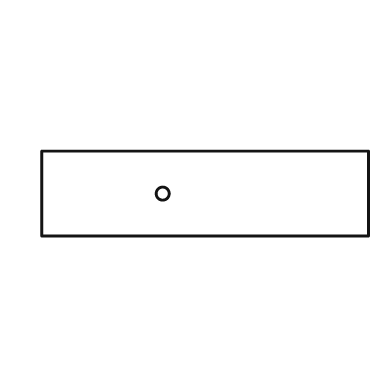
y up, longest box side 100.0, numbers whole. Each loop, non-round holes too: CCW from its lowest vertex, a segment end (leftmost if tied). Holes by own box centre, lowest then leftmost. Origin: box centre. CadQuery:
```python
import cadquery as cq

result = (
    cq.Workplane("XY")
    .moveTo(-50.0, -13.0)
    .lineTo(50.0, -13.0)
    .lineTo(50.0, 13.0)
    .lineTo(-50.0, 13.0)
    .close()
    .moveTo(-13.0, 0.0)
    .circle(2.0)
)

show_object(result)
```